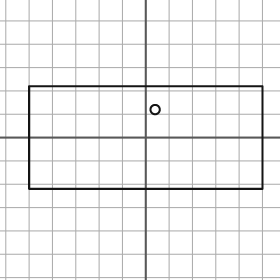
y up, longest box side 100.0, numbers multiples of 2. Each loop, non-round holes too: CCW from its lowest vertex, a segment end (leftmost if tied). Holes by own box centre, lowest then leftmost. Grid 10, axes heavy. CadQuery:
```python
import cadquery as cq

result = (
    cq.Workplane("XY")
    .moveTo(-50.0, -22.0)
    .lineTo(50.0, -22.0)
    .lineTo(50.0, 22.0)
    .lineTo(-50.0, 22.0)
    .close()
    .moveTo(4.0, 12.0)
    .circle(2.0)
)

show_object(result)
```